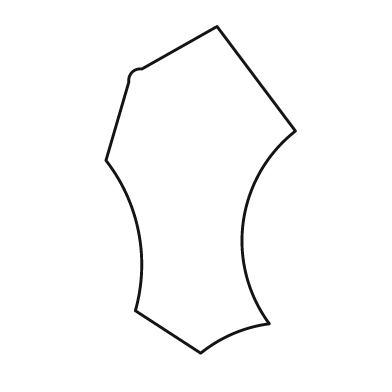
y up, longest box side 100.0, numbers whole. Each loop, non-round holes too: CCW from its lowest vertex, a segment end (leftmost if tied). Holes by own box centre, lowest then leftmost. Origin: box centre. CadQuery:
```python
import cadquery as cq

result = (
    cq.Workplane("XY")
    .moveTo(0.0, -50.0)
    .threePointArc((10.0, -44.0), (21.0, -41.0))
    .threePointArc((13.0, -10.0), (29.0, 18.0))
    .lineTo(5.0, 50.0)
    .lineTo(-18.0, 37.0)
    .threePointArc((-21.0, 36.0), (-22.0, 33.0))
    .lineTo(-29.0, 9.0)
    .threePointArc((-19.0, -13.0), (-20.0, -37.0))
    .close()
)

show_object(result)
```